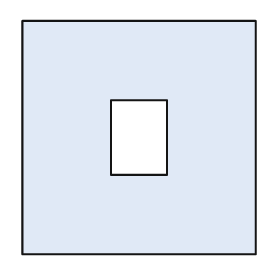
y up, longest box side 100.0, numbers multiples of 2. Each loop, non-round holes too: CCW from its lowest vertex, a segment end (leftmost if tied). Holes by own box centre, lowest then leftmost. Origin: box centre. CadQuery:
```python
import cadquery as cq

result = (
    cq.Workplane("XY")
    .moveTo(-50.0, -50.0)
    .lineTo(50.0, -50.0)
    .lineTo(50.0, 50.0)
    .lineTo(-50.0, 50.0)
    .close()
    .moveTo(-12.0, -16.0)
    .lineTo(12.0, -16.0)
    .lineTo(12.0, 16.0)
    .lineTo(-12.0, 16.0)
    .close()
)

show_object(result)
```